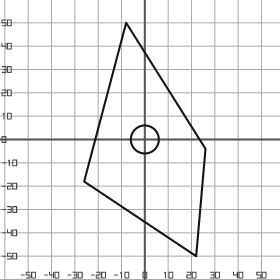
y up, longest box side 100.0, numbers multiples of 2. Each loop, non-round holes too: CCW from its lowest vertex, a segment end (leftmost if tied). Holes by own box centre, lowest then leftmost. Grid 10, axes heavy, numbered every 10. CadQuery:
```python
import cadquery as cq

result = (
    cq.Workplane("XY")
    .moveTo(22.0, -50.0)
    .lineTo(26.0, -4.0)
    .lineTo(-8.0, 50.0)
    .lineTo(-26.0, -18.0)
    .close()
    .moveTo(0.0, 0.0)
    .circle(6.0)
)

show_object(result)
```